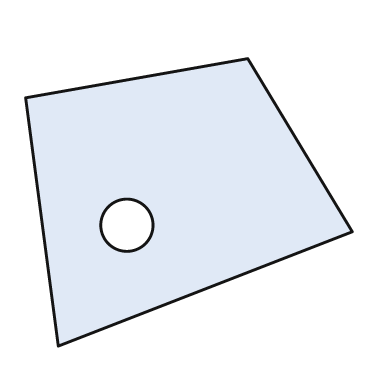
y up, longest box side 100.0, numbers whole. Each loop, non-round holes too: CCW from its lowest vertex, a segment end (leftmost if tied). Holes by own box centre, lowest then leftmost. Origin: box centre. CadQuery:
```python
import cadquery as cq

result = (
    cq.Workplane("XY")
    .moveTo(-40.0, -44.0)
    .lineTo(50.0, -9.0)
    .lineTo(18.0, 44.0)
    .lineTo(-50.0, 32.0)
    .close()
    .moveTo(-19.0, -7.0)
    .circle(8.0)
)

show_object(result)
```